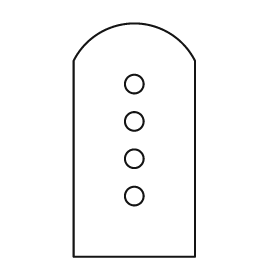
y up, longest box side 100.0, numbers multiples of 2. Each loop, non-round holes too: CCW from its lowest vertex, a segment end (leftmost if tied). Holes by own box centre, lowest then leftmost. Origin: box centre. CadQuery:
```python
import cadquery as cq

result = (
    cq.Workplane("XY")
    .moveTo(-26.0, -50.0)
    .lineTo(26.0, -50.0)
    .lineTo(26.0, 34.0)
    .threePointArc((0.0, 50.0), (-26.0, 34.0))
    .close()
    .moveTo(0.0, -24.0)
    .circle(4.0)
    .moveTo(0.0, -8.0)
    .circle(4.0)
    .moveTo(0.0, 8.0)
    .circle(4.0)
    .moveTo(0.0, 24.0)
    .circle(4.0)
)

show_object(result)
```